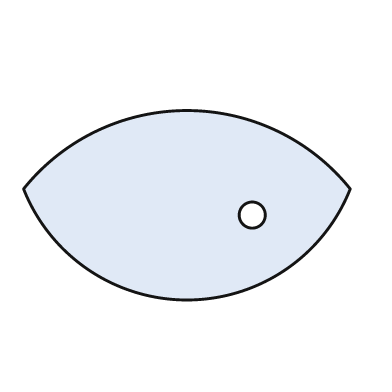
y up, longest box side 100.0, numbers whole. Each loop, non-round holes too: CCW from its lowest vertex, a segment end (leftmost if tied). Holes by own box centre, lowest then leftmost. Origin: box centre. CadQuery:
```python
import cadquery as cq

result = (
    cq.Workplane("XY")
    .moveTo(-50.0, 5.0)
    .threePointArc((0.0, -29.0), (50.0, 5.0))
    .threePointArc((0.0, 29.0), (-50.0, 5.0))
    .close()
    .moveTo(20.0, -3.0)
    .circle(4.0)
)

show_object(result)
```